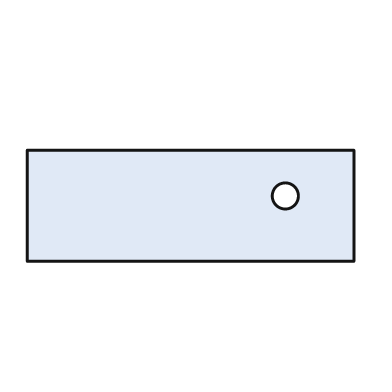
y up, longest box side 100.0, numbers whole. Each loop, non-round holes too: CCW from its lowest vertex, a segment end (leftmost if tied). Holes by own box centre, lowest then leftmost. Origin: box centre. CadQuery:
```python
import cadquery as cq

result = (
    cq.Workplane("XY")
    .moveTo(-50.0, -17.0)
    .lineTo(50.0, -17.0)
    .lineTo(50.0, 17.0)
    .lineTo(-50.0, 17.0)
    .close()
    .moveTo(29.0, 3.0)
    .circle(4.0)
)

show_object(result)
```